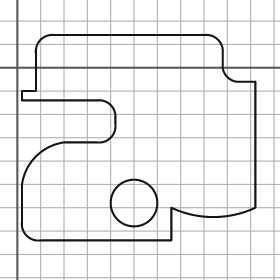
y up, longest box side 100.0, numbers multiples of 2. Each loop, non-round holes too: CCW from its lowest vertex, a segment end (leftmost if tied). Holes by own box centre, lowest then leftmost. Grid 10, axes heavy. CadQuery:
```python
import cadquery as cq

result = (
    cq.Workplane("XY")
    .moveTo(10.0, -74.0)
    .lineTo(66.0, -74.0)
    .lineTo(66.0, -60.0)
    .threePointArc((84.0, -64.0), (102.0, -60.0))
    .lineTo(102.0, -6.0)
    .lineTo(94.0, -6.0)
    .threePointArc((90.0, -4.0), (88.0, 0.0))
    .lineTo(88.0, 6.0)
    .threePointArc((86.0, 12.0), (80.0, 14.0))
    .lineTo(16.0, 14.0)
    .threePointArc((10.0, 12.0), (8.0, 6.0))
    .lineTo(8.0, -10.0)
    .lineTo(2.0, -10.0)
    .lineTo(2.0, -14.0)
    .lineTo(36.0, -14.0)
    .threePointArc((40.0, -16.0), (42.0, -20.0))
    .lineTo(42.0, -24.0)
    .threePointArc((40.0, -30.0), (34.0, -32.0))
    .lineTo(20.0, -32.0)
    .threePointArc((8.0, -38.0), (2.0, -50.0))
    .lineTo(2.0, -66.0)
    .threePointArc((4.0, -72.0), (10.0, -74.0))
    .close()
    .moveTo(50.0, -58.0)
    .circle(10.0)
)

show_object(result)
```